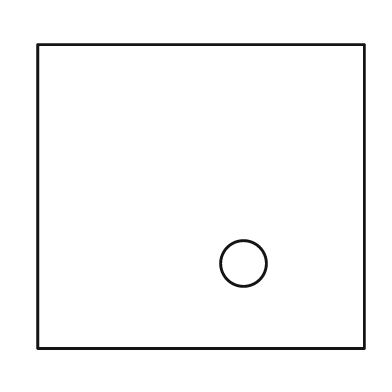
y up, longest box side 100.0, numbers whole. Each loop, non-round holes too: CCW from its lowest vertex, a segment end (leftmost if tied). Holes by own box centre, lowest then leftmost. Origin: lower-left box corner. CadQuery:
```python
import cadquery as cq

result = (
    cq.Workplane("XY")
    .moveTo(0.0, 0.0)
    .lineTo(100.0, 0.0)
    .lineTo(100.0, 93.0)
    .lineTo(0.0, 93.0)
    .close()
    .moveTo(63.0, 26.0)
    .circle(7.0)
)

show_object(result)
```